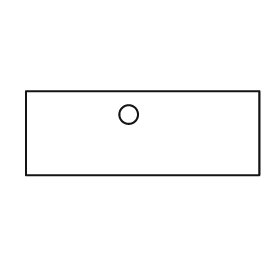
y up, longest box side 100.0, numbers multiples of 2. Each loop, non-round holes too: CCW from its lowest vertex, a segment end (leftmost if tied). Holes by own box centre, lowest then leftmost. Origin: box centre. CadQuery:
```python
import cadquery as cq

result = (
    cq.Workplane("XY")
    .moveTo(-50.0, -18.0)
    .lineTo(50.0, -18.0)
    .lineTo(50.0, 18.0)
    .lineTo(-50.0, 18.0)
    .close()
    .moveTo(-6.0, 8.0)
    .circle(4.0)
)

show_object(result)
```